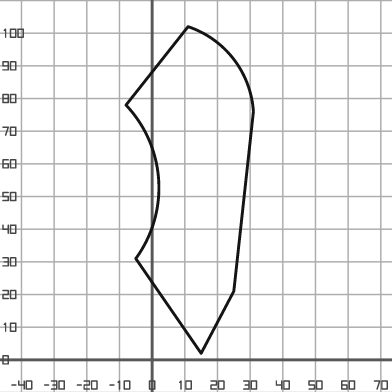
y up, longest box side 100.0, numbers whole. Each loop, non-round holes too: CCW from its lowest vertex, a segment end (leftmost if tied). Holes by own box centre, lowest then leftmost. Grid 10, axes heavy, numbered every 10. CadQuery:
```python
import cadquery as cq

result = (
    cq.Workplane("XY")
    .moveTo(15.0, 2.0)
    .lineTo(25.0, 21.0)
    .lineTo(31.0, 76.0)
    .threePointArc((25.0, 92.0), (11.0, 102.0))
    .lineTo(-8.0, 78.0)
    .threePointArc((2.0, 55.0), (-5.0, 31.0))
    .close()
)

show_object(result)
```